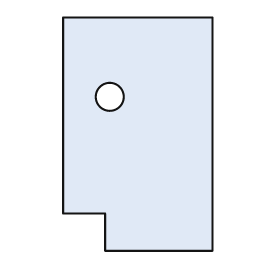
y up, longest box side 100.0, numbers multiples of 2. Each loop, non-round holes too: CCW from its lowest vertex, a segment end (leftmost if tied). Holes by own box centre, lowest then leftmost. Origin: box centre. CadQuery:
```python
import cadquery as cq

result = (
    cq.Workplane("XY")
    .moveTo(-14.0, -50.0)
    .lineTo(32.0, -50.0)
    .lineTo(32.0, 50.0)
    .lineTo(-32.0, 50.0)
    .lineTo(-32.0, -34.0)
    .lineTo(-14.0, -34.0)
    .close()
    .moveTo(-12.0, 16.0)
    .circle(6.0)
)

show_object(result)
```